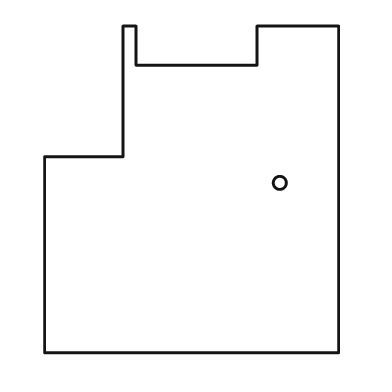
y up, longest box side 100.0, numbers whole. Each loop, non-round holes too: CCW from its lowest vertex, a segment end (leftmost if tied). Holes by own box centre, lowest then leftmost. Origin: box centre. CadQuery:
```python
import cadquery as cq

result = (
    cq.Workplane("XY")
    .moveTo(-45.0, -50.0)
    .lineTo(45.0, -50.0)
    .lineTo(45.0, 50.0)
    .lineTo(20.0, 50.0)
    .lineTo(20.0, 38.0)
    .lineTo(-17.0, 38.0)
    .lineTo(-17.0, 50.0)
    .lineTo(-21.0, 50.0)
    .lineTo(-21.0, 10.0)
    .lineTo(-45.0, 10.0)
    .close()
    .moveTo(27.0, 2.0)
    .circle(2.0)
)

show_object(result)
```